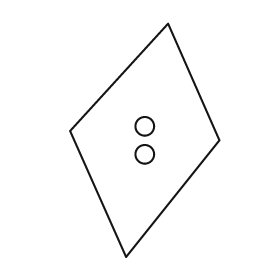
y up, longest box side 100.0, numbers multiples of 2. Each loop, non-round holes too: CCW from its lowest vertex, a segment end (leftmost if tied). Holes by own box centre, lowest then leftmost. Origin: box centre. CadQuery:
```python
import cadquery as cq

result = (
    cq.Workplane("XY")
    .moveTo(-8.0, -50.0)
    .lineTo(32.0, 0.0)
    .lineTo(10.0, 50.0)
    .lineTo(-32.0, 4.0)
    .close()
    .moveTo(0.0, -6.0)
    .circle(4.0)
    .moveTo(0.0, 6.0)
    .circle(4.0)
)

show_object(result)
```